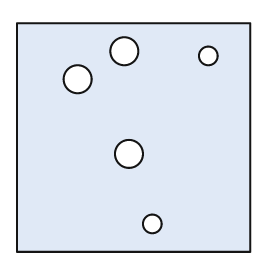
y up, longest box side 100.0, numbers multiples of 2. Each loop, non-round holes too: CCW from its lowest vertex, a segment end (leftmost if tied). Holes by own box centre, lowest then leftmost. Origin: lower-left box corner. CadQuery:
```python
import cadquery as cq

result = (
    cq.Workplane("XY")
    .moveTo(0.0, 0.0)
    .lineTo(100.0, 0.0)
    .lineTo(100.0, 98.0)
    .lineTo(0.0, 98.0)
    .close()
    .moveTo(58.0, 12.0)
    .circle(4.0)
    .moveTo(48.0, 42.0)
    .circle(6.0)
    .moveTo(26.0, 74.0)
    .circle(6.0)
    .moveTo(82.0, 84.0)
    .circle(4.0)
    .moveTo(46.0, 86.0)
    .circle(6.0)
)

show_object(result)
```